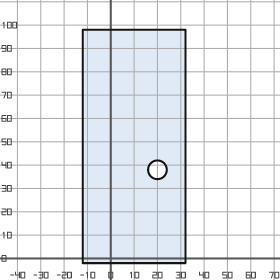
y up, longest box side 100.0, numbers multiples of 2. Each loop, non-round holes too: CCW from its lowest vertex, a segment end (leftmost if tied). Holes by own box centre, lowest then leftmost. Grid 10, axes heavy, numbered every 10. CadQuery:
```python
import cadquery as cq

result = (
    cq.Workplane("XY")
    .moveTo(-12.0, -2.0)
    .lineTo(32.0, -2.0)
    .lineTo(32.0, 98.0)
    .lineTo(-12.0, 98.0)
    .close()
    .moveTo(20.0, 38.0)
    .circle(4.0)
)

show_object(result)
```